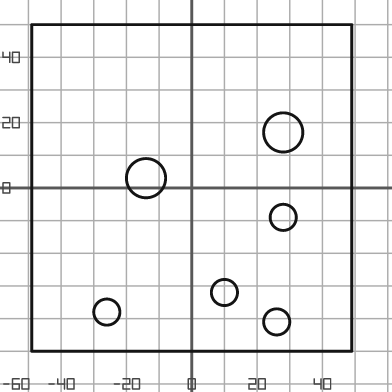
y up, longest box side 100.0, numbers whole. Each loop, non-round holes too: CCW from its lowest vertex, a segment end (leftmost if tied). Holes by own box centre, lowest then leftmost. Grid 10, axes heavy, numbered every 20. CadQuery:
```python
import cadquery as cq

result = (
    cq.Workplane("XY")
    .moveTo(-49.0, -50.0)
    .lineTo(49.0, -50.0)
    .lineTo(49.0, 50.0)
    .lineTo(-49.0, 50.0)
    .close()
    .moveTo(26.0, -41.0)
    .circle(4.0)
    .moveTo(-26.0, -38.0)
    .circle(4.0)
    .moveTo(10.0, -32.0)
    .circle(4.0)
    .moveTo(28.0, -9.0)
    .circle(4.0)
    .moveTo(-14.0, 3.0)
    .circle(6.0)
    .moveTo(28.0, 17.0)
    .circle(6.0)
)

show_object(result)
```